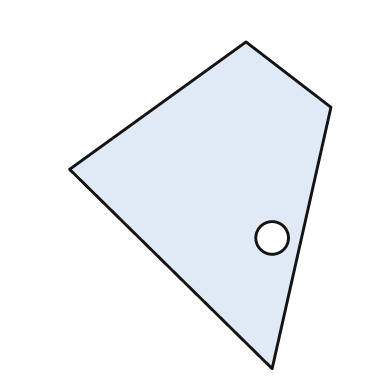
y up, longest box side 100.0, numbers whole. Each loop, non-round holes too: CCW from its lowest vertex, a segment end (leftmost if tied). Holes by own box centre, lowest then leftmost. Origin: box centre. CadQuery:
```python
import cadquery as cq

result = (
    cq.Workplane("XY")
    .moveTo(22.0, -50.0)
    .lineTo(40.0, 30.0)
    .lineTo(14.0, 50.0)
    .lineTo(-40.0, 11.0)
    .close()
    .moveTo(22.0, -10.0)
    .circle(5.0)
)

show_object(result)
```